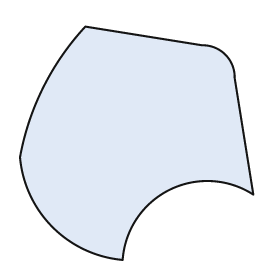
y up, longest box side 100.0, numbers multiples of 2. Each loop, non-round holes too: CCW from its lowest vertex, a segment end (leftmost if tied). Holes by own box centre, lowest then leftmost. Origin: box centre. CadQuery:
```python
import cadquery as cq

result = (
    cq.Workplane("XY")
    .moveTo(-6.0, -50.0)
    .threePointArc((14.0, -20.0), (50.0, -22.0))
    .lineTo(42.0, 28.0)
    .threePointArc((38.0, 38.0), (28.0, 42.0))
    .lineTo(-22.0, 50.0)
    .threePointArc((-40.0, 24.0), (-50.0, -6.0))
    .threePointArc((-36.0, -36.0), (-6.0, -50.0))
    .close()
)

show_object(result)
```